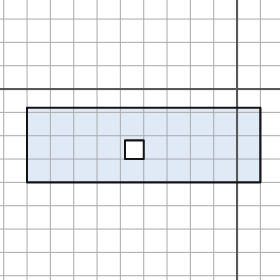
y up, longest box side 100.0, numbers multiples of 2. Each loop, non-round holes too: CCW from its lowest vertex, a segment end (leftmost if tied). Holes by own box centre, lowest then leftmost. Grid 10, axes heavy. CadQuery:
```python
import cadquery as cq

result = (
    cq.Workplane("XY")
    .moveTo(-90.0, -40.0)
    .lineTo(10.0, -40.0)
    .lineTo(10.0, -8.0)
    .lineTo(-90.0, -8.0)
    .close()
    .moveTo(-48.0, -30.0)
    .lineTo(-40.0, -30.0)
    .lineTo(-40.0, -22.0)
    .lineTo(-48.0, -22.0)
    .close()
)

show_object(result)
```